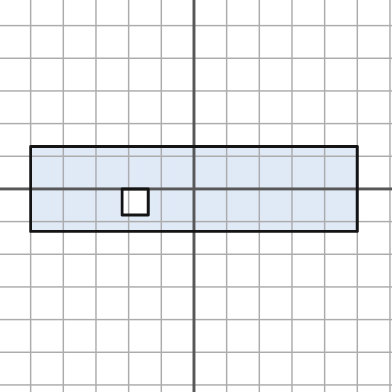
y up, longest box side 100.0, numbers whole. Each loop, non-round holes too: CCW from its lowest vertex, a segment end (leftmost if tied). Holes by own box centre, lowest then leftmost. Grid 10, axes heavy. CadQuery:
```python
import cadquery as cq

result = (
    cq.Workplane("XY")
    .moveTo(-50.0, -13.0)
    .lineTo(50.0, -13.0)
    .lineTo(50.0, 13.0)
    .lineTo(-50.0, 13.0)
    .close()
    .moveTo(-22.0, -8.0)
    .lineTo(-14.0, -8.0)
    .lineTo(-14.0, 0.0)
    .lineTo(-22.0, 0.0)
    .close()
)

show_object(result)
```